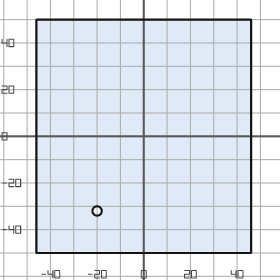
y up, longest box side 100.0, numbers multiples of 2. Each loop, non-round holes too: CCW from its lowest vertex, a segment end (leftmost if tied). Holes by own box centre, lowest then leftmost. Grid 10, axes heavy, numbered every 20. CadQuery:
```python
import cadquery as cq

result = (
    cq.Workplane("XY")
    .moveTo(-46.0, -50.0)
    .lineTo(46.0, -50.0)
    .lineTo(46.0, 50.0)
    .lineTo(-46.0, 50.0)
    .close()
    .moveTo(-20.0, -32.0)
    .circle(2.0)
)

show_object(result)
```